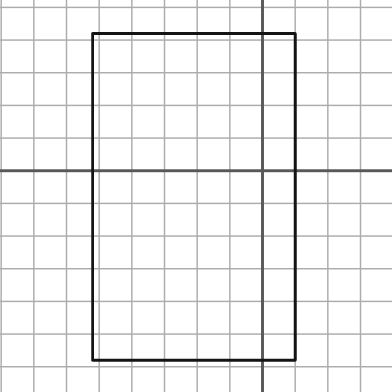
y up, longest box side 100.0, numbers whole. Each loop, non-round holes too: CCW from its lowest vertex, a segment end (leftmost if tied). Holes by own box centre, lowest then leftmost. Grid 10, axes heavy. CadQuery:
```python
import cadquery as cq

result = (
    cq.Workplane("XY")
    .moveTo(-52.0, -58.0)
    .lineTo(10.0, -58.0)
    .lineTo(10.0, 42.0)
    .lineTo(-52.0, 42.0)
    .close()
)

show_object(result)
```